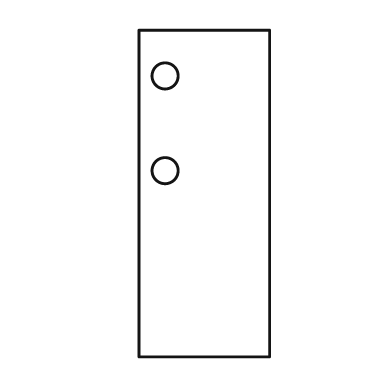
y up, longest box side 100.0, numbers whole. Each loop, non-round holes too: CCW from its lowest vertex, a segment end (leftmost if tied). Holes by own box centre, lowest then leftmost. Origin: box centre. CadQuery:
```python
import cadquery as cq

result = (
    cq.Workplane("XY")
    .moveTo(-20.0, -50.0)
    .lineTo(20.0, -50.0)
    .lineTo(20.0, 50.0)
    .lineTo(-20.0, 50.0)
    .close()
    .moveTo(-12.0, 7.0)
    .circle(4.0)
    .moveTo(-12.0, 36.0)
    .circle(4.0)
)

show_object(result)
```